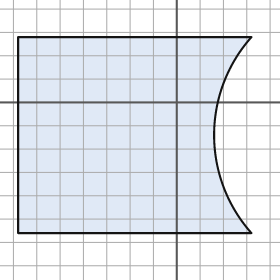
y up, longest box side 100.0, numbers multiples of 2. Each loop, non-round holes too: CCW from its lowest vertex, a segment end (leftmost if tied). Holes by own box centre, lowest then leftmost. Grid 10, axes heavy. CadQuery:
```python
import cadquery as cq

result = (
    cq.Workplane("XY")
    .moveTo(-68.0, -56.0)
    .lineTo(32.0, -56.0)
    .threePointArc((16.0, -14.0), (32.0, 28.0))
    .lineTo(-68.0, 28.0)
    .close()
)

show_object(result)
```